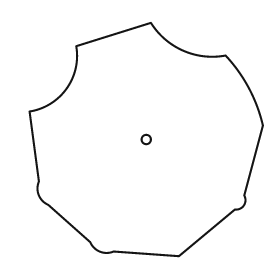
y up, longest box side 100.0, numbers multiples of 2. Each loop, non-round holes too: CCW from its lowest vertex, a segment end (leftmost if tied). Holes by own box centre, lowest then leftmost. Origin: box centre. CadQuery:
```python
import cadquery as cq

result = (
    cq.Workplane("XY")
    .moveTo(14.0, -50.0)
    .lineTo(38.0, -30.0)
    .threePointArc((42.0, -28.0), (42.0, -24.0))
    .lineTo(50.0, 6.0)
    .threePointArc((44.0, 22.0), (34.0, 36.0))
    .threePointArc((16.0, 38.0), (2.0, 50.0))
    .lineTo(-30.0, 40.0)
    .threePointArc((-34.0, 22.0), (-50.0, 12.0))
    .lineTo(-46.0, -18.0)
    .threePointArc((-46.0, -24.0), (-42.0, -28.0))
    .lineTo(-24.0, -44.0)
    .threePointArc((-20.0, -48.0), (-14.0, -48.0))
    .close()
    .moveTo(0.0, 0.0)
    .circle(2.0)
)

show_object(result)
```